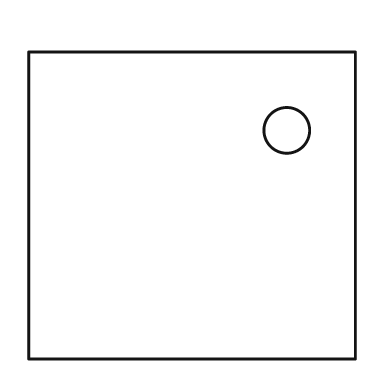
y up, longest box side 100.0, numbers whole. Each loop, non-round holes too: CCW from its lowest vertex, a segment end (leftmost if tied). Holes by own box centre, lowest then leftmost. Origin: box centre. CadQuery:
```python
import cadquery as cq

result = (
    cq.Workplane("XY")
    .moveTo(-50.0, -47.0)
    .lineTo(50.0, -47.0)
    .lineTo(50.0, 47.0)
    .lineTo(-50.0, 47.0)
    .close()
    .moveTo(29.0, 23.0)
    .circle(7.0)
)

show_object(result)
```